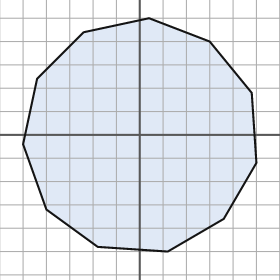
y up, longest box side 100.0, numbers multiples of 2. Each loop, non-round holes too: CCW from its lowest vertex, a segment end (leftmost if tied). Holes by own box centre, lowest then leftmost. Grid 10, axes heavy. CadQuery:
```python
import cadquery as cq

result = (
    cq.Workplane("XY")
    .moveTo(12.0, -50.0)
    .lineTo(36.0, -36.0)
    .lineTo(50.0, -12.0)
    .lineTo(48.0, 18.0)
    .lineTo(30.0, 40.0)
    .lineTo(4.0, 50.0)
    .lineTo(-24.0, 44.0)
    .lineTo(-44.0, 24.0)
    .lineTo(-50.0, -4.0)
    .lineTo(-40.0, -32.0)
    .lineTo(-18.0, -48.0)
    .close()
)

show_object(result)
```